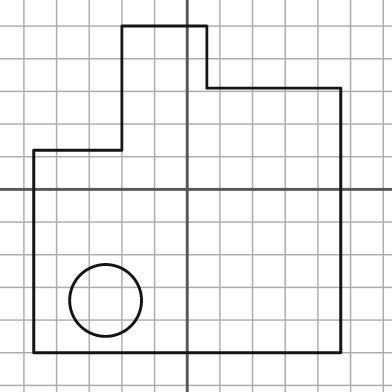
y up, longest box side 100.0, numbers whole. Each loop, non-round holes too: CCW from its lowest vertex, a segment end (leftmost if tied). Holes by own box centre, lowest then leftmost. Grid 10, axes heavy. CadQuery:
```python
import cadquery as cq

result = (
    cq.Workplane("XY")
    .moveTo(-47.0, -50.0)
    .lineTo(47.0, -50.0)
    .lineTo(47.0, 31.0)
    .lineTo(6.0, 31.0)
    .lineTo(6.0, 50.0)
    .lineTo(-20.0, 50.0)
    .lineTo(-20.0, 12.0)
    .lineTo(-47.0, 12.0)
    .close()
    .moveTo(-25.0, -34.0)
    .circle(11.0)
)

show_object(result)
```